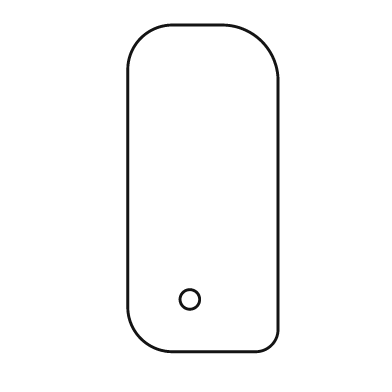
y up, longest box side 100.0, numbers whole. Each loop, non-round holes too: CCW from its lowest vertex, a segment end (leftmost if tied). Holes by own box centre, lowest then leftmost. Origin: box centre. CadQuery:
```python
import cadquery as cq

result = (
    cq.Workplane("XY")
    .moveTo(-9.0, -50.0)
    .lineTo(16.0, -50.0)
    .threePointArc((21.0, -48.0), (23.0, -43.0))
    .lineTo(23.0, 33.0)
    .threePointArc((18.0, 45.0), (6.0, 50.0))
    .lineTo(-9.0, 50.0)
    .threePointArc((-19.0, 46.0), (-23.0, 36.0))
    .lineTo(-23.0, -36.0)
    .threePointArc((-19.0, -46.0), (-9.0, -50.0))
    .close()
    .moveTo(-4.0, -34.0)
    .circle(3.0)
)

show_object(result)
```